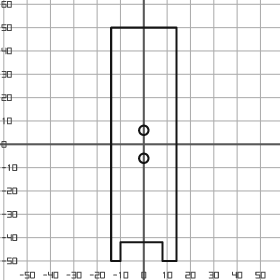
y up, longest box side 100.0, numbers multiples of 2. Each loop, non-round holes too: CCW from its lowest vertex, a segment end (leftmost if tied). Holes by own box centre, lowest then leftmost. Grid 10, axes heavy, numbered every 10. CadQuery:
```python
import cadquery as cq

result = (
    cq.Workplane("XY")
    .moveTo(-14.0, -50.0)
    .lineTo(-10.0, -50.0)
    .lineTo(-10.0, -42.0)
    .lineTo(8.0, -42.0)
    .lineTo(8.0, -50.0)
    .lineTo(14.0, -50.0)
    .lineTo(14.0, 50.0)
    .lineTo(-14.0, 50.0)
    .close()
    .moveTo(0.0, -6.0)
    .circle(2.0)
    .moveTo(0.0, 6.0)
    .circle(2.0)
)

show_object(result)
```